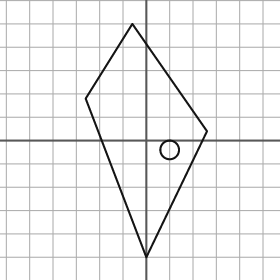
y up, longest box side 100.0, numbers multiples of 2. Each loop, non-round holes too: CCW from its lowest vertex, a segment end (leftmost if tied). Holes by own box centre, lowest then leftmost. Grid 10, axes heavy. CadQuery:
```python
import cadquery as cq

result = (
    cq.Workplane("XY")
    .moveTo(0.0, -50.0)
    .lineTo(26.0, 4.0)
    .lineTo(-6.0, 50.0)
    .lineTo(-26.0, 18.0)
    .close()
    .moveTo(10.0, -4.0)
    .circle(4.0)
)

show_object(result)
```